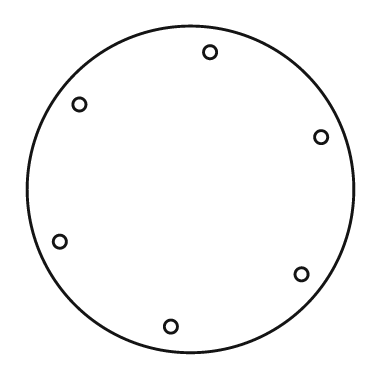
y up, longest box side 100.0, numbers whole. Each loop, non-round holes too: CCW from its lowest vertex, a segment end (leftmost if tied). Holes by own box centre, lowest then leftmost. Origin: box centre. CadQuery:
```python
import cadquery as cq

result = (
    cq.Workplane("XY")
    .moveTo(0.0, 0.0)
    .circle(50.0)
    .moveTo(-6.0, -42.0)
    .circle(2.0)
    .moveTo(34.0, -26.0)
    .circle(2.0)
    .moveTo(-40.0, -16.0)
    .circle(2.0)
    .moveTo(40.0, 16.0)
    .circle(2.0)
    .moveTo(-34.0, 26.0)
    .circle(2.0)
    .moveTo(6.0, 42.0)
    .circle(2.0)
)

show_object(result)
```